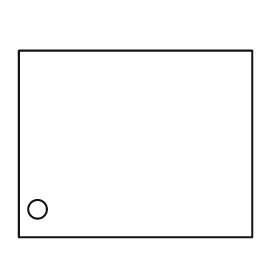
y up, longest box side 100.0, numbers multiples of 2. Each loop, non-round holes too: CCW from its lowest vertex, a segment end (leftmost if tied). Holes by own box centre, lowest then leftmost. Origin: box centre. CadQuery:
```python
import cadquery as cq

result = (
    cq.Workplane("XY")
    .moveTo(-50.0, -40.0)
    .lineTo(50.0, -40.0)
    .lineTo(50.0, 40.0)
    .lineTo(-50.0, 40.0)
    .close()
    .moveTo(-42.0, -28.0)
    .circle(4.0)
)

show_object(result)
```